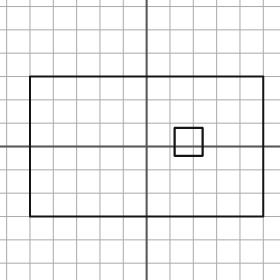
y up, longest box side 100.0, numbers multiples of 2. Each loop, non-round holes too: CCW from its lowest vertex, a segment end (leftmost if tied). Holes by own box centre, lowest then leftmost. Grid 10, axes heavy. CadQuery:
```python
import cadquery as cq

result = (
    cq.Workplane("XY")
    .moveTo(-50.0, -30.0)
    .lineTo(50.0, -30.0)
    .lineTo(50.0, 30.0)
    .lineTo(-50.0, 30.0)
    .close()
    .moveTo(12.0, -4.0)
    .lineTo(24.0, -4.0)
    .lineTo(24.0, 8.0)
    .lineTo(12.0, 8.0)
    .close()
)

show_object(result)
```